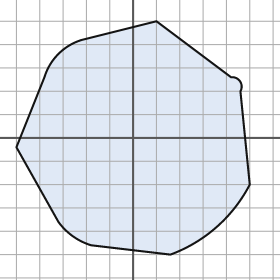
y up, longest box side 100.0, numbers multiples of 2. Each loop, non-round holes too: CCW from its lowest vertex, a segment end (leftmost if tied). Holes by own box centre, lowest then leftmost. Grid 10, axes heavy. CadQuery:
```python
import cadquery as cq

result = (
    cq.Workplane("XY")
    .moveTo(16.0, -50.0)
    .threePointArc((36.0, -38.0), (50.0, -20.0))
    .lineTo(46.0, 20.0)
    .threePointArc((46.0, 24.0), (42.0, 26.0))
    .lineTo(10.0, 50.0)
    .lineTo(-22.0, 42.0)
    .threePointArc((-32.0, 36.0), (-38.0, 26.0))
    .lineTo(-50.0, -4.0)
    .lineTo(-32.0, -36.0)
    .threePointArc((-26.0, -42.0), (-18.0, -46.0))
    .close()
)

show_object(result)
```